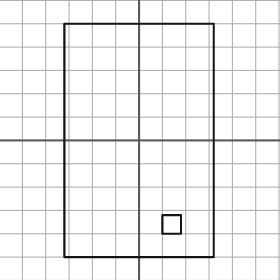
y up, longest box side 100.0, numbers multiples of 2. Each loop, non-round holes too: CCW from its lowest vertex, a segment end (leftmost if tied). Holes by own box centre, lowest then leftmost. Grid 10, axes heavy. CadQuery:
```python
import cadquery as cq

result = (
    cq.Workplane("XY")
    .moveTo(-32.0, -50.0)
    .lineTo(32.0, -50.0)
    .lineTo(32.0, 50.0)
    .lineTo(-32.0, 50.0)
    .close()
    .moveTo(10.0, -40.0)
    .lineTo(18.0, -40.0)
    .lineTo(18.0, -32.0)
    .lineTo(10.0, -32.0)
    .close()
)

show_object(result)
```